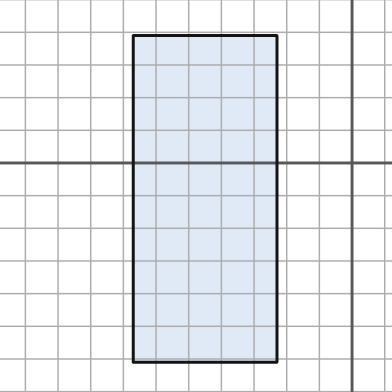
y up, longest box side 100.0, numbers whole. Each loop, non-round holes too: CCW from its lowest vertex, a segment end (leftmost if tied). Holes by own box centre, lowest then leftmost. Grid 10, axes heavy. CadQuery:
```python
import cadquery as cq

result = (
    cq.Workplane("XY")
    .moveTo(-67.0, -61.0)
    .lineTo(-23.0, -61.0)
    .lineTo(-23.0, 39.0)
    .lineTo(-67.0, 39.0)
    .close()
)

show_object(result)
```